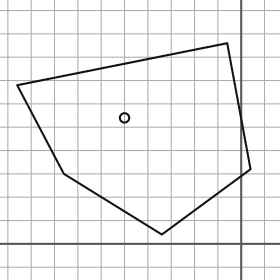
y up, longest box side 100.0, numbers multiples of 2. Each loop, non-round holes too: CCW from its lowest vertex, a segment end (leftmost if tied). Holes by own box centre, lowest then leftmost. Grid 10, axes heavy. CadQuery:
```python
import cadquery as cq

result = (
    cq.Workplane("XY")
    .moveTo(-34.0, 4.0)
    .lineTo(4.0, 32.0)
    .lineTo(-6.0, 86.0)
    .lineTo(-96.0, 68.0)
    .lineTo(-76.0, 30.0)
    .close()
    .moveTo(-50.0, 54.0)
    .circle(2.0)
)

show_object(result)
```